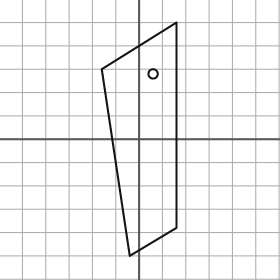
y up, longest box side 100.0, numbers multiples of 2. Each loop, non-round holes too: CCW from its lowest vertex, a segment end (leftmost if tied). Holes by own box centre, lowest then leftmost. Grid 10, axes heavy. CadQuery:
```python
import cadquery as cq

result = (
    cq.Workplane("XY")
    .moveTo(-4.0, -50.0)
    .lineTo(16.0, -38.0)
    .lineTo(16.0, 50.0)
    .lineTo(-16.0, 30.0)
    .close()
    .moveTo(6.0, 28.0)
    .circle(2.0)
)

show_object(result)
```